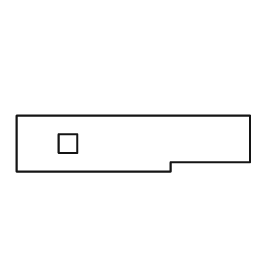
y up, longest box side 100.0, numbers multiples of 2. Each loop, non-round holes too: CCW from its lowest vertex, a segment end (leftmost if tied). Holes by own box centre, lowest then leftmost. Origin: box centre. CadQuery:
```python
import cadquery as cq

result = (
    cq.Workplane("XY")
    .moveTo(-50.0, -12.0)
    .lineTo(16.0, -12.0)
    .lineTo(16.0, -8.0)
    .lineTo(50.0, -8.0)
    .lineTo(50.0, 12.0)
    .lineTo(-50.0, 12.0)
    .close()
    .moveTo(-32.0, -4.0)
    .lineTo(-24.0, -4.0)
    .lineTo(-24.0, 4.0)
    .lineTo(-32.0, 4.0)
    .close()
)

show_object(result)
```